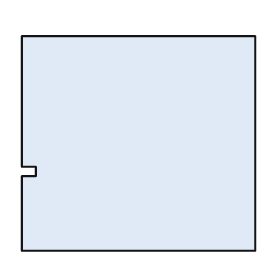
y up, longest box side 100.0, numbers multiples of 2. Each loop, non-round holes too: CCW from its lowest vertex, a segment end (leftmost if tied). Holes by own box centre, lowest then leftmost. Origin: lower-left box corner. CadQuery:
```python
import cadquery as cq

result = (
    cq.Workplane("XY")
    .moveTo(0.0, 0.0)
    .lineTo(100.0, 0.0)
    .lineTo(100.0, 92.0)
    .lineTo(0.0, 92.0)
    .lineTo(0.0, 36.0)
    .lineTo(6.0, 36.0)
    .lineTo(6.0, 32.0)
    .lineTo(0.0, 32.0)
    .close()
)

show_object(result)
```